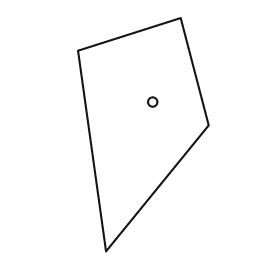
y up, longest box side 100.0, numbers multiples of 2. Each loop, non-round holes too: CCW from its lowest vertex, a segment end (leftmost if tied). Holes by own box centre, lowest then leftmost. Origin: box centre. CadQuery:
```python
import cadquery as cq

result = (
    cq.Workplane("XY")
    .moveTo(-16.0, -50.0)
    .lineTo(28.0, 4.0)
    .lineTo(16.0, 50.0)
    .lineTo(-28.0, 36.0)
    .close()
    .moveTo(4.0, 14.0)
    .circle(2.0)
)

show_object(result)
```